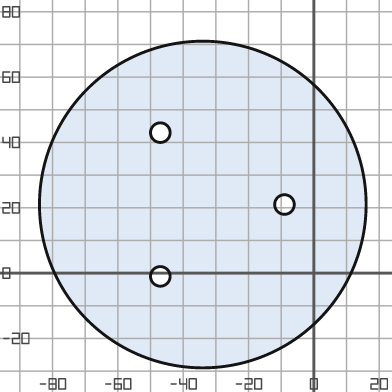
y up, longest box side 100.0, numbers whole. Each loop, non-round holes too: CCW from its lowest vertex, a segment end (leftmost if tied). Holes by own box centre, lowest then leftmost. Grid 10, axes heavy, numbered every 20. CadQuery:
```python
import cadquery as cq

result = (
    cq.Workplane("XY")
    .moveTo(-34.0, 21.0)
    .circle(50.0)
    .moveTo(-47.0, -1.0)
    .circle(3.0)
    .moveTo(-9.0, 21.0)
    .circle(3.0)
    .moveTo(-47.0, 43.0)
    .circle(3.0)
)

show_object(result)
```